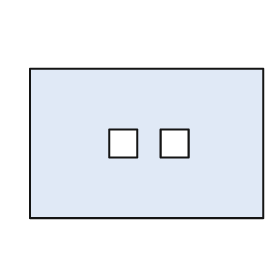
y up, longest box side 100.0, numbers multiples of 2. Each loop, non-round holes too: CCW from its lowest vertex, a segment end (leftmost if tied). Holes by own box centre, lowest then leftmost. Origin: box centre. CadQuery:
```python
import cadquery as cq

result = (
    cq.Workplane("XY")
    .moveTo(-50.0, -32.0)
    .lineTo(50.0, -32.0)
    .lineTo(50.0, 32.0)
    .lineTo(-50.0, 32.0)
    .close()
    .moveTo(-16.0, -6.0)
    .lineTo(-4.0, -6.0)
    .lineTo(-4.0, 6.0)
    .lineTo(-16.0, 6.0)
    .close()
    .moveTo(6.0, -6.0)
    .lineTo(18.0, -6.0)
    .lineTo(18.0, 6.0)
    .lineTo(6.0, 6.0)
    .close()
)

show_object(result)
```